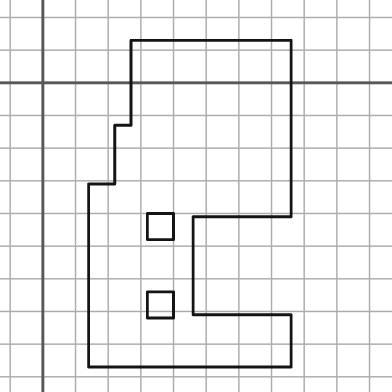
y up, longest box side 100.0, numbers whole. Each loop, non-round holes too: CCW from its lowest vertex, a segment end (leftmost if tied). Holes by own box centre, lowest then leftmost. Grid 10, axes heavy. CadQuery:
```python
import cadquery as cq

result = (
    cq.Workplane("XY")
    .moveTo(14.0, -87.0)
    .lineTo(76.0, -87.0)
    .lineTo(76.0, -71.0)
    .lineTo(46.0, -71.0)
    .lineTo(46.0, -41.0)
    .lineTo(76.0, -41.0)
    .lineTo(76.0, 13.0)
    .lineTo(27.0, 13.0)
    .lineTo(27.0, -13.0)
    .lineTo(22.0, -13.0)
    .lineTo(22.0, -31.0)
    .lineTo(14.0, -31.0)
    .close()
    .moveTo(32.0, -72.0)
    .lineTo(40.0, -72.0)
    .lineTo(40.0, -64.0)
    .lineTo(32.0, -64.0)
    .close()
    .moveTo(32.0, -48.0)
    .lineTo(40.0, -48.0)
    .lineTo(40.0, -40.0)
    .lineTo(32.0, -40.0)
    .close()
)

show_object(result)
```